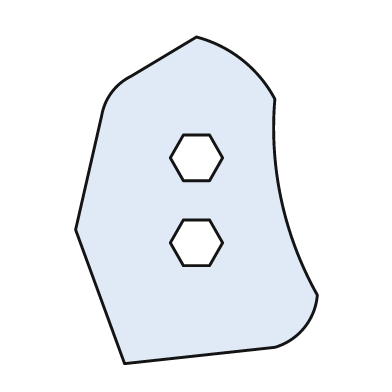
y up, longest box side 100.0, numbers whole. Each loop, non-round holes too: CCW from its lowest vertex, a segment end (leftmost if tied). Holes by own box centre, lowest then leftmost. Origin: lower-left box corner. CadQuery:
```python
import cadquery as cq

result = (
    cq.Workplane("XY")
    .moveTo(15.0, 0.0)
    .lineTo(61.0, 5.0)
    .threePointArc((70.0, 11.0), (74.0, 21.0))
    .threePointArc((63.0, 50.0), (61.0, 81.0))
    .threePointArc((51.0, 93.0), (37.0, 100.0))
    .lineTo(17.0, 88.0)
    .threePointArc((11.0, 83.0), (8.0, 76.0))
    .lineTo(0.0, 41.0)
    .close()
    .moveTo(33.0, 30.0)
    .lineTo(41.0, 30.0)
    .lineTo(45.0, 37.0)
    .lineTo(41.0, 44.0)
    .lineTo(33.0, 44.0)
    .lineTo(29.0, 37.0)
    .close()
    .moveTo(33.0, 56.0)
    .lineTo(41.0, 56.0)
    .lineTo(45.0, 63.0)
    .lineTo(41.0, 70.0)
    .lineTo(33.0, 70.0)
    .lineTo(29.0, 63.0)
    .close()
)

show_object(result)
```